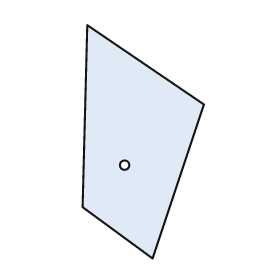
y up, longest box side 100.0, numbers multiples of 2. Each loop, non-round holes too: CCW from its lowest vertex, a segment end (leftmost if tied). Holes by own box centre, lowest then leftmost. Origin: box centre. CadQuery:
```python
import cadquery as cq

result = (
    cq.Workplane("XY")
    .moveTo(4.0, -50.0)
    .lineTo(26.0, 16.0)
    .lineTo(-24.0, 50.0)
    .lineTo(-26.0, -28.0)
    .close()
    .moveTo(-8.0, -10.0)
    .circle(2.0)
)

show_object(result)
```